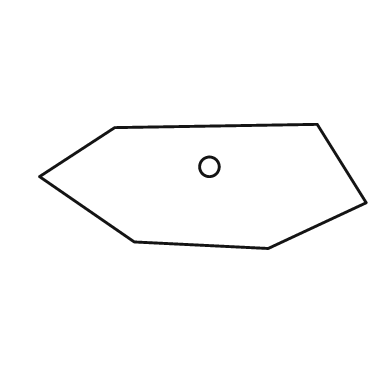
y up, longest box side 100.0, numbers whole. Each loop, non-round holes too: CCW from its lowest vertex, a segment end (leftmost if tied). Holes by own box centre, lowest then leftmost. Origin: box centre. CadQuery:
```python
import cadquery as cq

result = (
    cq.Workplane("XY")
    .moveTo(20.0, -19.0)
    .lineTo(50.0, -5.0)
    .lineTo(35.0, 19.0)
    .lineTo(-27.0, 18.0)
    .lineTo(-50.0, 3.0)
    .lineTo(-21.0, -17.0)
    .close()
    .moveTo(2.0, 6.0)
    .circle(3.0)
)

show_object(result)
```